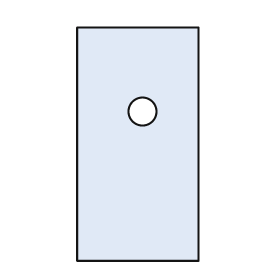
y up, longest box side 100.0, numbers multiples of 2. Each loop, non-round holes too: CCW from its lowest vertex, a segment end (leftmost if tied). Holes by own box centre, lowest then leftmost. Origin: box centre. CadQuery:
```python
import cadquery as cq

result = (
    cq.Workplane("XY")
    .moveTo(-26.0, -50.0)
    .lineTo(26.0, -50.0)
    .lineTo(26.0, 50.0)
    .lineTo(-26.0, 50.0)
    .close()
    .moveTo(2.0, 14.0)
    .circle(6.0)
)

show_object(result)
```